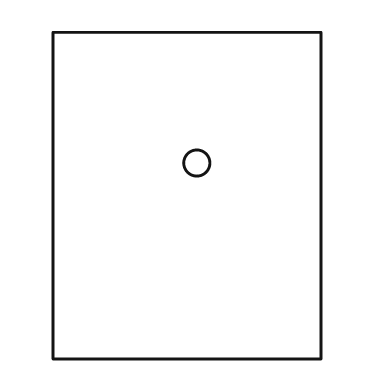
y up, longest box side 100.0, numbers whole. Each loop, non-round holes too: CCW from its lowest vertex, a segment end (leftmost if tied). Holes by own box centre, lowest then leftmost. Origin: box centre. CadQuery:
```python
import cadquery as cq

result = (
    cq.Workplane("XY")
    .moveTo(-41.0, -50.0)
    .lineTo(41.0, -50.0)
    .lineTo(41.0, 50.0)
    .lineTo(-41.0, 50.0)
    .close()
    .moveTo(3.0, 10.0)
    .circle(4.0)
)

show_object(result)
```